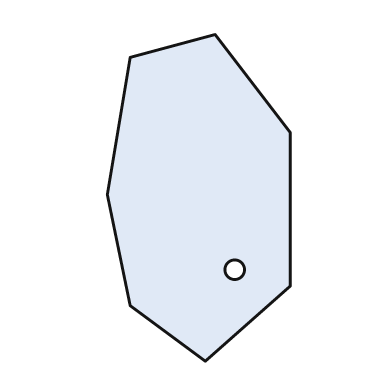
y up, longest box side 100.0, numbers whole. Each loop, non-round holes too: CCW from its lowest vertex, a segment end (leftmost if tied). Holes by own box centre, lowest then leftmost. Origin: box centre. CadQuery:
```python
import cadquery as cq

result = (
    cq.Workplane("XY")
    .moveTo(2.0, -50.0)
    .lineTo(28.0, -27.0)
    .lineTo(28.0, 20.0)
    .lineTo(5.0, 50.0)
    .lineTo(-21.0, 43.0)
    .lineTo(-28.0, 1.0)
    .lineTo(-21.0, -33.0)
    .close()
    .moveTo(11.0, -22.0)
    .circle(3.0)
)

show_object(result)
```